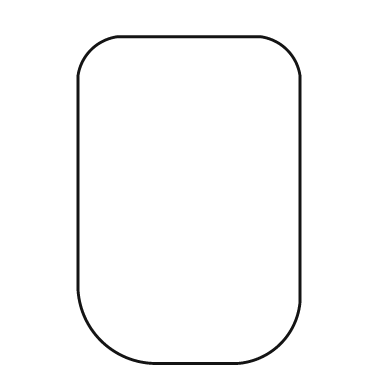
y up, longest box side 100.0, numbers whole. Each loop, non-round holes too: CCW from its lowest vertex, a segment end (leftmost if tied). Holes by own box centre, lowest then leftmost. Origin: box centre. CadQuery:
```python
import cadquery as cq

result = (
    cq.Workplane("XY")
    .moveTo(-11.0, -50.0)
    .lineTo(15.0, -50.0)
    .threePointArc((28.0, -44.0), (34.0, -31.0))
    .lineTo(34.0, 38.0)
    .threePointArc((30.0, 46.0), (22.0, 50.0))
    .lineTo(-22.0, 50.0)
    .threePointArc((-30.0, 46.0), (-34.0, 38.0))
    .lineTo(-34.0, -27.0)
    .threePointArc((-27.0, -43.0), (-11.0, -50.0))
    .close()
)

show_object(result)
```